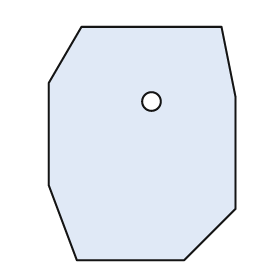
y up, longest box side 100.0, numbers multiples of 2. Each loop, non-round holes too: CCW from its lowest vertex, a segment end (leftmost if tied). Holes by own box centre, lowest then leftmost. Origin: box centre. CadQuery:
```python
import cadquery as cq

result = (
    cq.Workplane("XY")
    .moveTo(-28.0, -50.0)
    .lineTo(18.0, -50.0)
    .lineTo(40.0, -28.0)
    .lineTo(40.0, 20.0)
    .lineTo(34.0, 50.0)
    .lineTo(-26.0, 50.0)
    .lineTo(-40.0, 26.0)
    .lineTo(-40.0, -18.0)
    .close()
    .moveTo(4.0, 18.0)
    .circle(4.0)
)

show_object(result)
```